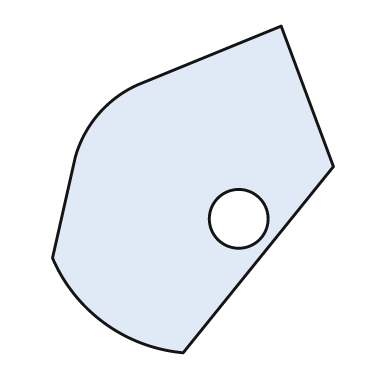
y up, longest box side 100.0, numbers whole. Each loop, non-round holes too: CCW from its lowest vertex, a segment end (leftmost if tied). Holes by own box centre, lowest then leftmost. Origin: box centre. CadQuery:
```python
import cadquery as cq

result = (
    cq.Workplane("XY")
    .moveTo(-3.0, -50.0)
    .lineTo(43.0, 7.0)
    .lineTo(27.0, 50.0)
    .lineTo(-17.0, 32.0)
    .threePointArc((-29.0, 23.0), (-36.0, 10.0))
    .lineTo(-43.0, -21.0)
    .threePointArc((-27.0, -41.0), (-3.0, -50.0))
    .close()
    .moveTo(14.0, -9.0)
    .circle(9.0)
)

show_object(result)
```